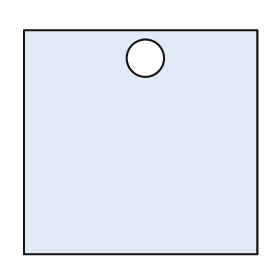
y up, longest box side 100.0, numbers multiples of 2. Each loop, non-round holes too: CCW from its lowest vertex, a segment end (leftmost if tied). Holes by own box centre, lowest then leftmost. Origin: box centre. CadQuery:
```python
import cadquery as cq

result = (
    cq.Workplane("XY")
    .moveTo(-50.0, -48.0)
    .lineTo(50.0, -48.0)
    .lineTo(50.0, 48.0)
    .lineTo(-50.0, 48.0)
    .close()
    .moveTo(2.0, 36.0)
    .circle(8.0)
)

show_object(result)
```